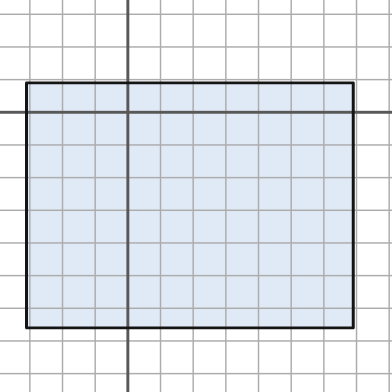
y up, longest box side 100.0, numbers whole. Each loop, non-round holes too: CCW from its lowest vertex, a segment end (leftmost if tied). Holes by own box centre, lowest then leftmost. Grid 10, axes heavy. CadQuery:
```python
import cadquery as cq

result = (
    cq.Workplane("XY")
    .moveTo(-31.0, -66.0)
    .lineTo(69.0, -66.0)
    .lineTo(69.0, 9.0)
    .lineTo(-31.0, 9.0)
    .close()
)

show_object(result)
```